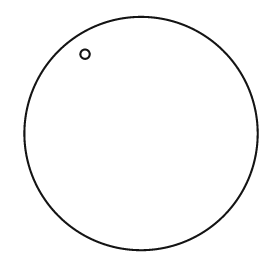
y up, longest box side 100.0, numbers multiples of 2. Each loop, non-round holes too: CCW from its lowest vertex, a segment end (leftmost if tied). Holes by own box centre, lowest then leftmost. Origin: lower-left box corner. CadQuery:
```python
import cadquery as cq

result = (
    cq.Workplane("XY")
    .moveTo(50.0, 50.0)
    .circle(50.0)
    .moveTo(26.0, 84.0)
    .circle(2.0)
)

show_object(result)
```